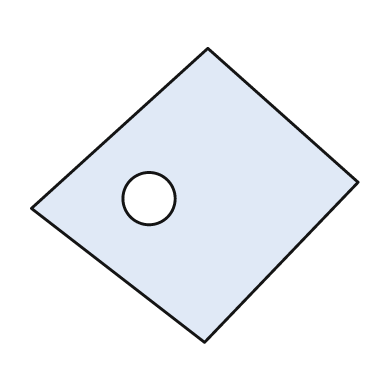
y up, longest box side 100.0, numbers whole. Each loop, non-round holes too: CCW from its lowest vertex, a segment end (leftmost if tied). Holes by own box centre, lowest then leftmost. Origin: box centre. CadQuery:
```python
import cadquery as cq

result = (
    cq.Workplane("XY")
    .moveTo(3.0, -45.0)
    .lineTo(50.0, 4.0)
    .lineTo(4.0, 45.0)
    .lineTo(-50.0, -4.0)
    .close()
    .moveTo(-14.0, -1.0)
    .circle(8.0)
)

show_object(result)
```